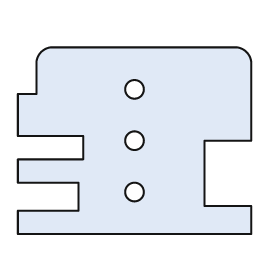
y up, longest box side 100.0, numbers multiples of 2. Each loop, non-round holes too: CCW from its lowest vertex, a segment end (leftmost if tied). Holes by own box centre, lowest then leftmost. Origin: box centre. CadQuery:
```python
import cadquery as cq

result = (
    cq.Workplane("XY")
    .moveTo(-50.0, -40.0)
    .lineTo(50.0, -40.0)
    .lineTo(50.0, -28.0)
    .lineTo(30.0, -28.0)
    .lineTo(30.0, 0.0)
    .lineTo(50.0, 0.0)
    .lineTo(50.0, 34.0)
    .threePointArc((48.0, 38.0), (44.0, 40.0))
    .lineTo(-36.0, 40.0)
    .threePointArc((-40.0, 38.0), (-42.0, 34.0))
    .lineTo(-42.0, 20.0)
    .lineTo(-50.0, 20.0)
    .lineTo(-50.0, 2.0)
    .lineTo(-22.0, 2.0)
    .lineTo(-22.0, -8.0)
    .lineTo(-50.0, -8.0)
    .lineTo(-50.0, -18.0)
    .lineTo(-24.0, -18.0)
    .lineTo(-24.0, -30.0)
    .lineTo(-50.0, -30.0)
    .close()
    .moveTo(0.0, -22.0)
    .circle(4.0)
    .moveTo(0.0, 0.0)
    .circle(4.0)
    .moveTo(0.0, 22.0)
    .circle(4.0)
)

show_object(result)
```